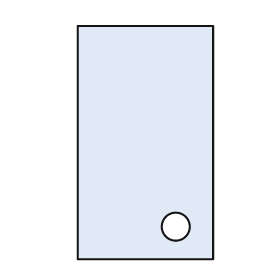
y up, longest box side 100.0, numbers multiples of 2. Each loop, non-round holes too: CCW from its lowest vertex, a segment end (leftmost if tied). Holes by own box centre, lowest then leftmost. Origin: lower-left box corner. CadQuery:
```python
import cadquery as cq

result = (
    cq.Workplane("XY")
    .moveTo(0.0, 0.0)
    .lineTo(58.0, 0.0)
    .lineTo(58.0, 100.0)
    .lineTo(0.0, 100.0)
    .close()
    .moveTo(42.0, 14.0)
    .circle(6.0)
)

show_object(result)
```